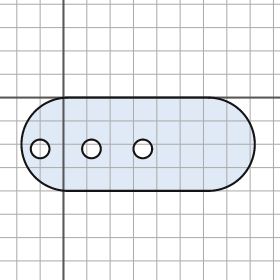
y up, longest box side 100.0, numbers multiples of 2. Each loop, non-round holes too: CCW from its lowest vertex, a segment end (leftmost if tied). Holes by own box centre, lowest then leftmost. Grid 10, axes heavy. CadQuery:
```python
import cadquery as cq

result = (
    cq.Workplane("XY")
    .moveTo(2.0, -40.0)
    .lineTo(62.0, -40.0)
    .threePointArc((82.0, -20.0), (62.0, 0.0))
    .lineTo(2.0, 0.0)
    .threePointArc((-18.0, -20.0), (2.0, -40.0))
    .close()
    .moveTo(-10.0, -22.0)
    .circle(4.0)
    .moveTo(12.0, -22.0)
    .circle(4.0)
    .moveTo(34.0, -22.0)
    .circle(4.0)
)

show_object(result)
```